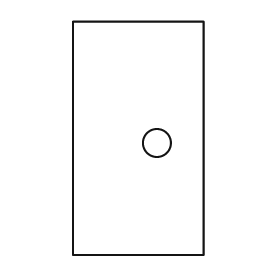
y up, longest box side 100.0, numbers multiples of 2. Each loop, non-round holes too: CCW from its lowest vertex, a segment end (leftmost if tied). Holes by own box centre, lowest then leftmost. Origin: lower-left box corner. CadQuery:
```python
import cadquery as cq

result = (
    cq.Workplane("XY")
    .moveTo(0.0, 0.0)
    .lineTo(56.0, 0.0)
    .lineTo(56.0, 100.0)
    .lineTo(0.0, 100.0)
    .close()
    .moveTo(36.0, 48.0)
    .circle(6.0)
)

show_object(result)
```